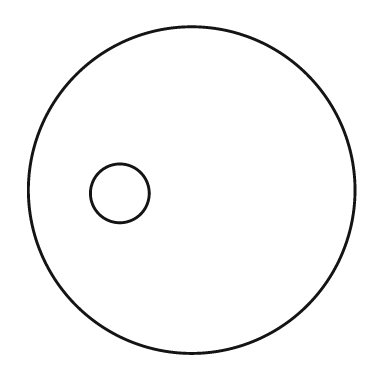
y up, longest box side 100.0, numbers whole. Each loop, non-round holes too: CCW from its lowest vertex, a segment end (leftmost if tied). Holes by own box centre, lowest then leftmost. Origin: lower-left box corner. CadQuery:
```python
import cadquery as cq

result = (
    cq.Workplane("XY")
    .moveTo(50.0, 50.0)
    .circle(50.0)
    .moveTo(28.0, 49.0)
    .circle(9.0)
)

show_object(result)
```